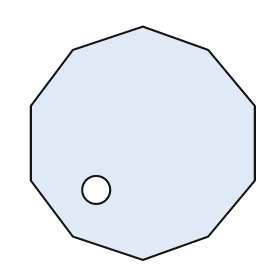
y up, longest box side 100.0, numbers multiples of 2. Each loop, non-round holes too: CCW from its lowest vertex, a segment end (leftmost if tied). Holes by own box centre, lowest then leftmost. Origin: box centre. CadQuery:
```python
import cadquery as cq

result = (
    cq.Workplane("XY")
    .moveTo(0.0, -50.0)
    .lineTo(28.0, -40.0)
    .lineTo(48.0, -16.0)
    .lineTo(48.0, 16.0)
    .lineTo(28.0, 40.0)
    .lineTo(0.0, 50.0)
    .lineTo(-30.0, 40.0)
    .lineTo(-48.0, 16.0)
    .lineTo(-48.0, -16.0)
    .lineTo(-30.0, -40.0)
    .close()
    .moveTo(-20.0, -20.0)
    .circle(6.0)
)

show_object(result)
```